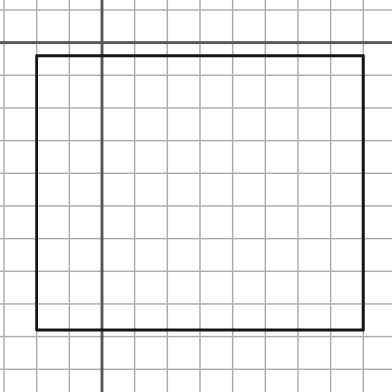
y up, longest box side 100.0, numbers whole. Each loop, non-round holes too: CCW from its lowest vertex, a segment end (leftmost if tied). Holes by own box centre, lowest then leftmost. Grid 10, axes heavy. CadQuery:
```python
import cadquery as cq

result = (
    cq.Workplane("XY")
    .moveTo(-20.0, -88.0)
    .lineTo(80.0, -88.0)
    .lineTo(80.0, -4.0)
    .lineTo(-20.0, -4.0)
    .close()
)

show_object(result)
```